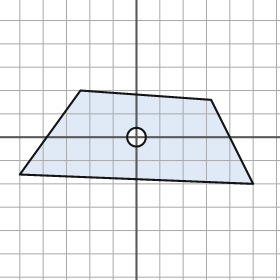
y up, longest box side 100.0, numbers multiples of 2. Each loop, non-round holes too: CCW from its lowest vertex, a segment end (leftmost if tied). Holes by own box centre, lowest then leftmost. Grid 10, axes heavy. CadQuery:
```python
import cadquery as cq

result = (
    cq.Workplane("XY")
    .moveTo(50.0, -20.0)
    .lineTo(32.0, 16.0)
    .lineTo(-24.0, 20.0)
    .lineTo(-50.0, -16.0)
    .close()
    .moveTo(0.0, 0.0)
    .circle(4.0)
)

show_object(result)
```